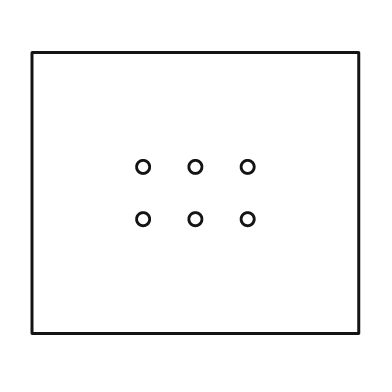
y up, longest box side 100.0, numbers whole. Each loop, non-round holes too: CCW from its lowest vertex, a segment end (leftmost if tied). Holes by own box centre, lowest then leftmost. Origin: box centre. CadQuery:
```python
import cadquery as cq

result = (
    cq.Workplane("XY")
    .moveTo(-50.0, -43.0)
    .lineTo(50.0, -43.0)
    .lineTo(50.0, 43.0)
    .lineTo(-50.0, 43.0)
    .close()
    .moveTo(-16.0, -8.0)
    .circle(2.0)
    .moveTo(0.0, -8.0)
    .circle(2.0)
    .moveTo(16.0, -8.0)
    .circle(2.0)
    .moveTo(-16.0, 8.0)
    .circle(2.0)
    .moveTo(0.0, 8.0)
    .circle(2.0)
    .moveTo(16.0, 8.0)
    .circle(2.0)
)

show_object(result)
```